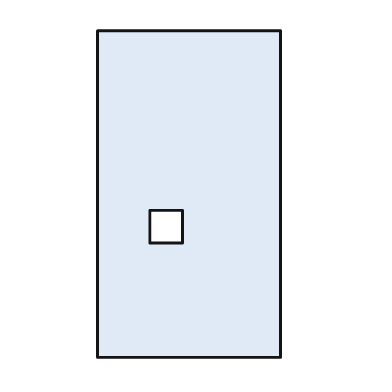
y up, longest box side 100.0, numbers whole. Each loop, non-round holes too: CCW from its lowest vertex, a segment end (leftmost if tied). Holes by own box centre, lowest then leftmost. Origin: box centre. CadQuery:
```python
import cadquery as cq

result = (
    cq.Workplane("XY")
    .moveTo(-28.0, -50.0)
    .lineTo(28.0, -50.0)
    .lineTo(28.0, 50.0)
    .lineTo(-28.0, 50.0)
    .close()
    .moveTo(-12.0, -15.0)
    .lineTo(-2.0, -15.0)
    .lineTo(-2.0, -5.0)
    .lineTo(-12.0, -5.0)
    .close()
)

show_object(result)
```